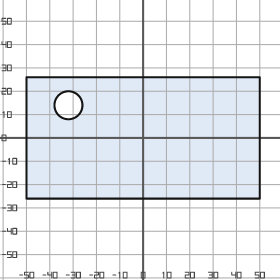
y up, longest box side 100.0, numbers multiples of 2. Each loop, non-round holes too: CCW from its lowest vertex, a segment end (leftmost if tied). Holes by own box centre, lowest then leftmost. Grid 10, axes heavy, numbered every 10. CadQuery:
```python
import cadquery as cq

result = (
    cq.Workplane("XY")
    .moveTo(-50.0, -26.0)
    .lineTo(50.0, -26.0)
    .lineTo(50.0, 26.0)
    .lineTo(-50.0, 26.0)
    .close()
    .moveTo(-32.0, 14.0)
    .circle(6.0)
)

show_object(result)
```